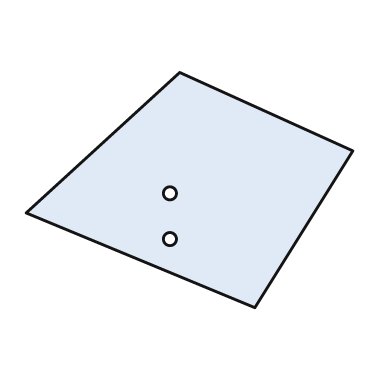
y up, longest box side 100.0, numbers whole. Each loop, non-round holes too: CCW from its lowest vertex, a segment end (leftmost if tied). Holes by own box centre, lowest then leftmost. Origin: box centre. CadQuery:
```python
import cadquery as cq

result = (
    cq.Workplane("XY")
    .moveTo(20.0, -36.0)
    .lineTo(50.0, 12.0)
    .lineTo(-3.0, 36.0)
    .lineTo(-50.0, -7.0)
    .close()
    .moveTo(-6.0, -15.0)
    .circle(2.0)
    .moveTo(-6.0, -1.0)
    .circle(2.0)
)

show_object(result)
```